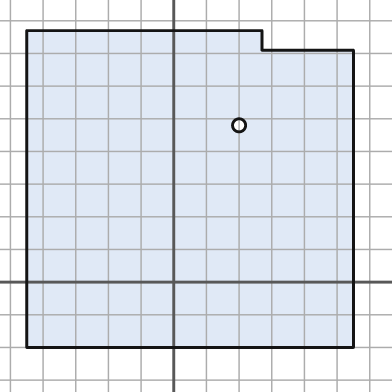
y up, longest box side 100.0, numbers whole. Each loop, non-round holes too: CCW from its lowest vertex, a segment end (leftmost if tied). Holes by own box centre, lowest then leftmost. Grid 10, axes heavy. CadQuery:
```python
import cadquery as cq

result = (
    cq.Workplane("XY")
    .moveTo(-45.0, -20.0)
    .lineTo(55.0, -20.0)
    .lineTo(55.0, 71.0)
    .lineTo(27.0, 71.0)
    .lineTo(27.0, 77.0)
    .lineTo(-45.0, 77.0)
    .close()
    .moveTo(20.0, 48.0)
    .circle(2.0)
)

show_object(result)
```